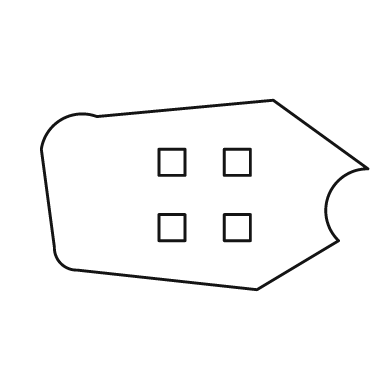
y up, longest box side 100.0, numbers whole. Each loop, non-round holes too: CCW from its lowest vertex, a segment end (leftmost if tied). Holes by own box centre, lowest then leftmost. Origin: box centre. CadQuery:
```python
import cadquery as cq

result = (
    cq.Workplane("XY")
    .moveTo(16.0, -29.0)
    .lineTo(41.0, -14.0)
    .threePointArc((38.0, 0.0), (50.0, 8.0))
    .lineTo(21.0, 29.0)
    .lineTo(-33.0, 24.0)
    .threePointArc((-44.0, 23.0), (-50.0, 14.0))
    .lineTo(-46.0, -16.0)
    .threePointArc((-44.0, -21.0), (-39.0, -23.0))
    .close()
    .moveTo(-14.0, -14.0)
    .lineTo(-6.0, -14.0)
    .lineTo(-6.0, -6.0)
    .lineTo(-14.0, -6.0)
    .close()
    .moveTo(6.0, -14.0)
    .lineTo(14.0, -14.0)
    .lineTo(14.0, -6.0)
    .lineTo(6.0, -6.0)
    .close()
    .moveTo(-14.0, 6.0)
    .lineTo(-6.0, 6.0)
    .lineTo(-6.0, 14.0)
    .lineTo(-14.0, 14.0)
    .close()
    .moveTo(6.0, 6.0)
    .lineTo(14.0, 6.0)
    .lineTo(14.0, 14.0)
    .lineTo(6.0, 14.0)
    .close()
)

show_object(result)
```